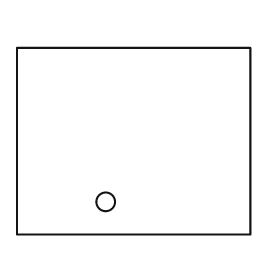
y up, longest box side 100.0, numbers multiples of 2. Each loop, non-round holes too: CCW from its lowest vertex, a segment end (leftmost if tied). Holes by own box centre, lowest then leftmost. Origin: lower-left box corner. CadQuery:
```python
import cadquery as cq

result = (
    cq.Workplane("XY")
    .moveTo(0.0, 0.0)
    .lineTo(100.0, 0.0)
    .lineTo(100.0, 80.0)
    .lineTo(0.0, 80.0)
    .close()
    .moveTo(38.0, 14.0)
    .circle(4.0)
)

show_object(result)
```